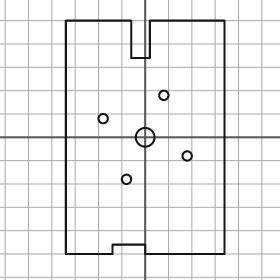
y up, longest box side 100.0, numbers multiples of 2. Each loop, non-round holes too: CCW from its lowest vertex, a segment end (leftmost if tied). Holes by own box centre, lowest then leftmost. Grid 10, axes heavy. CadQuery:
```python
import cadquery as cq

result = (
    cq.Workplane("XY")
    .moveTo(-34.0, -50.0)
    .lineTo(-14.0, -50.0)
    .lineTo(-14.0, -46.0)
    .lineTo(0.0, -46.0)
    .lineTo(0.0, -50.0)
    .lineTo(34.0, -50.0)
    .lineTo(34.0, 50.0)
    .lineTo(2.0, 50.0)
    .lineTo(2.0, 34.0)
    .lineTo(-6.0, 34.0)
    .lineTo(-6.0, 50.0)
    .lineTo(-34.0, 50.0)
    .close()
    .moveTo(-8.0, -18.0)
    .circle(2.0)
    .moveTo(18.0, -8.0)
    .circle(2.0)
    .moveTo(0.0, 0.0)
    .circle(4.0)
    .moveTo(-18.0, 8.0)
    .circle(2.0)
    .moveTo(8.0, 18.0)
    .circle(2.0)
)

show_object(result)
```